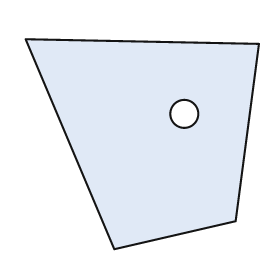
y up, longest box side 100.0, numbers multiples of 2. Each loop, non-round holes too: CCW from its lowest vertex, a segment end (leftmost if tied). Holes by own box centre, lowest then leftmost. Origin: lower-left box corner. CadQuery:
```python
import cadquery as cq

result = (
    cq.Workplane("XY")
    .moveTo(38.0, 0.0)
    .lineTo(90.0, 12.0)
    .lineTo(100.0, 88.0)
    .lineTo(0.0, 90.0)
    .close()
    .moveTo(68.0, 58.0)
    .circle(6.0)
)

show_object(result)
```